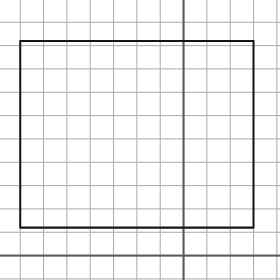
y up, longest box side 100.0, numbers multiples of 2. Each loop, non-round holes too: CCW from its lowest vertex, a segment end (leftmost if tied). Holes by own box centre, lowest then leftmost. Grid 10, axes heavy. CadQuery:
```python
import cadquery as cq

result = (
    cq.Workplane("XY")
    .moveTo(-70.0, 12.0)
    .lineTo(30.0, 12.0)
    .lineTo(30.0, 92.0)
    .lineTo(-70.0, 92.0)
    .close()
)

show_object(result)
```